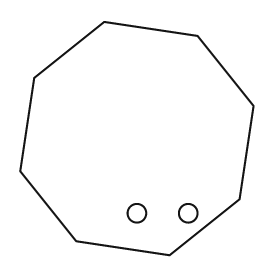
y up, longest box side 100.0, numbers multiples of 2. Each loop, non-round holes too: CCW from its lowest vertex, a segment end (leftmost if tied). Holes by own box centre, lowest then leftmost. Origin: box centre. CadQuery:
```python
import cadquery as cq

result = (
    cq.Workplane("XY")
    .moveTo(14.0, -50.0)
    .lineTo(44.0, -26.0)
    .lineTo(50.0, 14.0)
    .lineTo(26.0, 44.0)
    .lineTo(-14.0, 50.0)
    .lineTo(-44.0, 26.0)
    .lineTo(-50.0, -14.0)
    .lineTo(-26.0, -44.0)
    .close()
    .moveTo(0.0, -32.0)
    .circle(4.0)
    .moveTo(22.0, -32.0)
    .circle(4.0)
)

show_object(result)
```